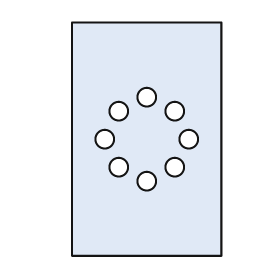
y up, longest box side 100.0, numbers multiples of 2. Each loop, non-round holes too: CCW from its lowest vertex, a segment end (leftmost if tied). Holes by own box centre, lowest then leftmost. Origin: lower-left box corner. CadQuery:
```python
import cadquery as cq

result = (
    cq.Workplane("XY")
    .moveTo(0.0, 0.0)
    .lineTo(64.0, 0.0)
    .lineTo(64.0, 100.0)
    .lineTo(0.0, 100.0)
    .close()
    .moveTo(32.0, 32.0)
    .circle(4.0)
    .moveTo(20.0, 38.0)
    .circle(4.0)
    .moveTo(44.0, 38.0)
    .circle(4.0)
    .moveTo(14.0, 50.0)
    .circle(4.0)
    .moveTo(50.0, 50.0)
    .circle(4.0)
    .moveTo(20.0, 62.0)
    .circle(4.0)
    .moveTo(44.0, 62.0)
    .circle(4.0)
    .moveTo(32.0, 68.0)
    .circle(4.0)
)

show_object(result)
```